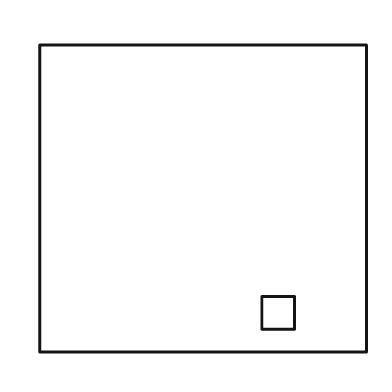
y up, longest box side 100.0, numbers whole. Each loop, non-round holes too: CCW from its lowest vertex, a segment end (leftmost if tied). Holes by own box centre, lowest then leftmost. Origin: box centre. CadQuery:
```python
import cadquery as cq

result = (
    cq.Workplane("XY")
    .moveTo(-50.0, -47.0)
    .lineTo(50.0, -47.0)
    .lineTo(50.0, 47.0)
    .lineTo(-50.0, 47.0)
    .close()
    .moveTo(18.0, -40.0)
    .lineTo(28.0, -40.0)
    .lineTo(28.0, -30.0)
    .lineTo(18.0, -30.0)
    .close()
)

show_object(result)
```